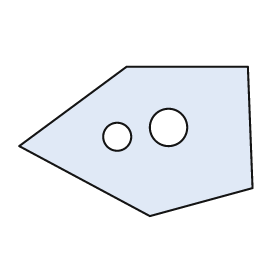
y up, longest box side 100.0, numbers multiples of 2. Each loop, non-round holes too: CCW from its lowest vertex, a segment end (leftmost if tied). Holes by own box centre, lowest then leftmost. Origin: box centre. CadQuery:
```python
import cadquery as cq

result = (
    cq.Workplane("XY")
    .moveTo(6.0, -32.0)
    .lineTo(50.0, -20.0)
    .lineTo(48.0, 32.0)
    .lineTo(-4.0, 32.0)
    .lineTo(-50.0, -2.0)
    .close()
    .moveTo(-8.0, 2.0)
    .circle(6.0)
    .moveTo(14.0, 6.0)
    .circle(8.0)
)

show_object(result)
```